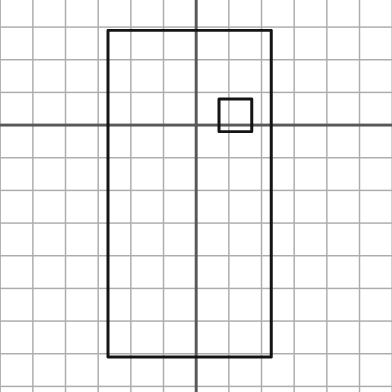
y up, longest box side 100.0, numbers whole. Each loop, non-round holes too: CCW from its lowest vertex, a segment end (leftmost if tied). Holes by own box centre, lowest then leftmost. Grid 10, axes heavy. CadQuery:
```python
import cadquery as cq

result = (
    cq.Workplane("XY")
    .moveTo(-27.0, -71.0)
    .lineTo(23.0, -71.0)
    .lineTo(23.0, 29.0)
    .lineTo(-27.0, 29.0)
    .close()
    .moveTo(7.0, -2.0)
    .lineTo(17.0, -2.0)
    .lineTo(17.0, 8.0)
    .lineTo(7.0, 8.0)
    .close()
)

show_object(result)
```